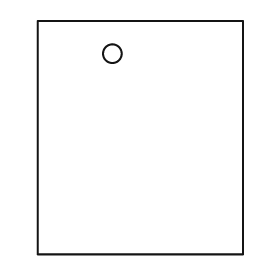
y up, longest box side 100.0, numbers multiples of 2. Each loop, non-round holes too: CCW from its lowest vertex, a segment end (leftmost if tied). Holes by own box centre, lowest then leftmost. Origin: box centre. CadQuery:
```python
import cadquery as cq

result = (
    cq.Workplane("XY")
    .moveTo(-44.0, -50.0)
    .lineTo(44.0, -50.0)
    .lineTo(44.0, 50.0)
    .lineTo(-44.0, 50.0)
    .close()
    .moveTo(-12.0, 36.0)
    .circle(4.0)
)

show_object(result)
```